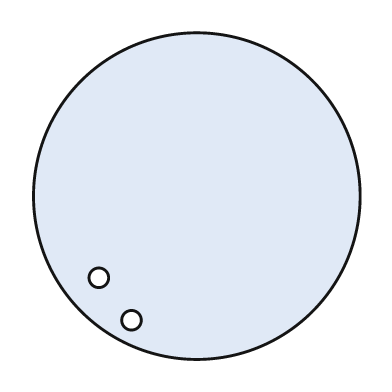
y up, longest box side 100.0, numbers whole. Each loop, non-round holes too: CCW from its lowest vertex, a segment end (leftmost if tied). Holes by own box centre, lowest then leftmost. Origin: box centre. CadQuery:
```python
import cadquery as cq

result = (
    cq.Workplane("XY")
    .moveTo(0.0, 0.0)
    .circle(50.0)
    .moveTo(-20.0, -38.0)
    .circle(3.0)
    .moveTo(-30.0, -25.0)
    .circle(3.0)
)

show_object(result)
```